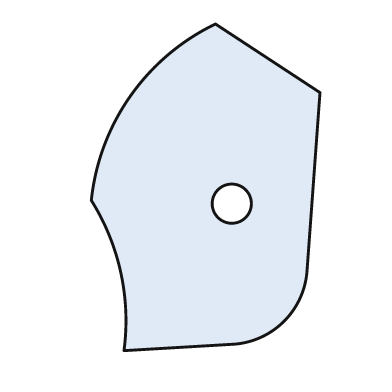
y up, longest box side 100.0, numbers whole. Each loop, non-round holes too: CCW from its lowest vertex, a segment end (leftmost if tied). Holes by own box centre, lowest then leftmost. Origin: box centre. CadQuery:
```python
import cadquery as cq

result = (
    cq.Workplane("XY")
    .moveTo(-25.0, -50.0)
    .lineTo(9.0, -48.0)
    .threePointArc((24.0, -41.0), (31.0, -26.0))
    .lineTo(35.0, 29.0)
    .lineTo(3.0, 50.0)
    .threePointArc((-23.0, 28.0), (-35.0, -4.0))
    .threePointArc((-26.0, -26.0), (-25.0, -50.0))
    .close()
    .moveTo(8.0, -5.0)
    .circle(6.0)
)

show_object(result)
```